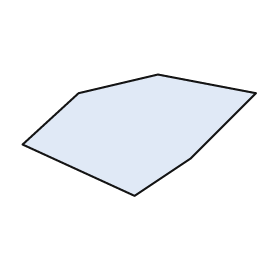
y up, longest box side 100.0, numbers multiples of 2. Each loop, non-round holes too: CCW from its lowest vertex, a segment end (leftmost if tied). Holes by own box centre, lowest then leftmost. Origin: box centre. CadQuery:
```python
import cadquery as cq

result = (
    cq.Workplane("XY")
    .moveTo(-2.0, -26.0)
    .lineTo(22.0, -10.0)
    .lineTo(50.0, 18.0)
    .lineTo(8.0, 26.0)
    .lineTo(-26.0, 18.0)
    .lineTo(-50.0, -4.0)
    .close()
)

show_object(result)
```